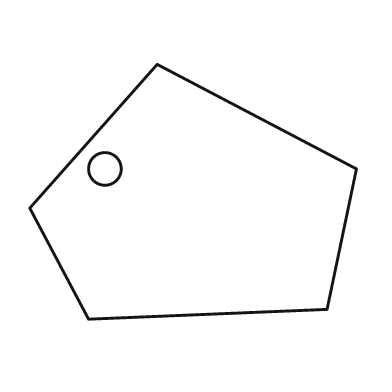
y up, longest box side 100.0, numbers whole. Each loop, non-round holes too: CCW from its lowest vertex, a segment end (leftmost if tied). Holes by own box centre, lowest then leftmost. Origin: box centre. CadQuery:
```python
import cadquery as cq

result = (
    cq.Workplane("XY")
    .moveTo(-32.0, -39.0)
    .lineTo(41.0, -36.0)
    .lineTo(50.0, 7.0)
    .lineTo(-11.0, 39.0)
    .lineTo(-50.0, -5.0)
    .close()
    .moveTo(-27.0, 7.0)
    .circle(5.0)
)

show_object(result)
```